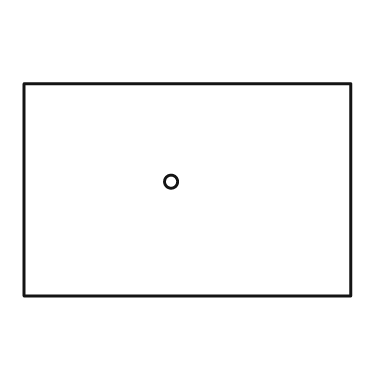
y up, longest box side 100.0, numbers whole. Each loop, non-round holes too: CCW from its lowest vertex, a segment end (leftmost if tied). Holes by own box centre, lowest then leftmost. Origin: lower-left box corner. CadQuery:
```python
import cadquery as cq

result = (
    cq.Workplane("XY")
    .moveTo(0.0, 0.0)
    .lineTo(100.0, 0.0)
    .lineTo(100.0, 65.0)
    .lineTo(0.0, 65.0)
    .close()
    .moveTo(45.0, 35.0)
    .circle(2.0)
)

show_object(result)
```